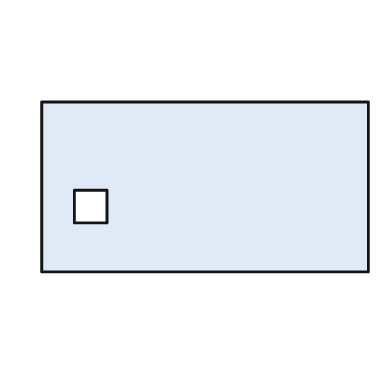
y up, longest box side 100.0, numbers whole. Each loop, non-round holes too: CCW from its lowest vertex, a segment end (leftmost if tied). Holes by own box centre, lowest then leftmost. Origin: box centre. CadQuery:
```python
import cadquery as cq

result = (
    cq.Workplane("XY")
    .moveTo(-50.0, -26.0)
    .lineTo(50.0, -26.0)
    .lineTo(50.0, 26.0)
    .lineTo(-50.0, 26.0)
    .close()
    .moveTo(-40.0, -11.0)
    .lineTo(-30.0, -11.0)
    .lineTo(-30.0, -1.0)
    .lineTo(-40.0, -1.0)
    .close()
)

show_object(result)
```